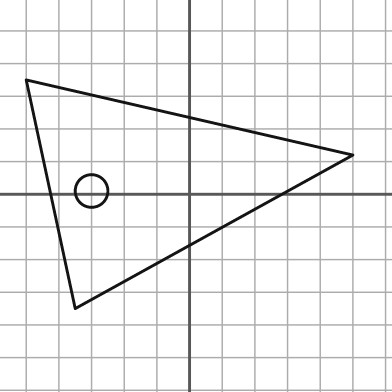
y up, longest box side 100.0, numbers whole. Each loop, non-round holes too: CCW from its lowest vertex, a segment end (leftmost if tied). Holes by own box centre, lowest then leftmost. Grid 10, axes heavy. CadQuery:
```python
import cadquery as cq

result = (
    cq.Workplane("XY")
    .moveTo(-35.0, -35.0)
    .lineTo(50.0, 12.0)
    .lineTo(-50.0, 35.0)
    .close()
    .moveTo(-30.0, 1.0)
    .circle(5.0)
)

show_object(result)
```